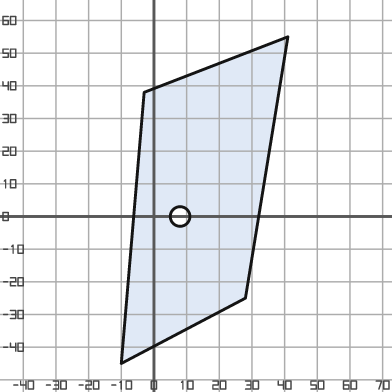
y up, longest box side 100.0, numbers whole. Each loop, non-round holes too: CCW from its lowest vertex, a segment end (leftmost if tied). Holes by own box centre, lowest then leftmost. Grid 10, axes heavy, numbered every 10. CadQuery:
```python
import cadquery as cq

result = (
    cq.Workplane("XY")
    .moveTo(-10.0, -45.0)
    .lineTo(28.0, -25.0)
    .lineTo(41.0, 55.0)
    .lineTo(-3.0, 38.0)
    .close()
    .moveTo(8.0, 0.0)
    .circle(3.0)
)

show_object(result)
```